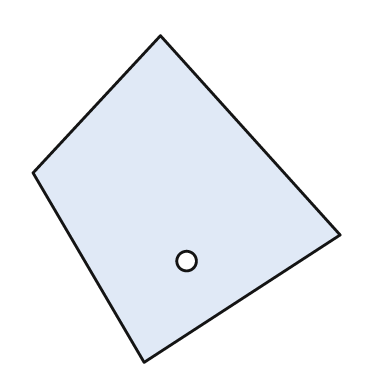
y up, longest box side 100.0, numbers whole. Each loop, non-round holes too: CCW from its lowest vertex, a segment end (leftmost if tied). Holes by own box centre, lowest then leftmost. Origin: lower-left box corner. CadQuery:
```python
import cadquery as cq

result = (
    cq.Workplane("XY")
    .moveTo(34.0, 0.0)
    .lineTo(94.0, 39.0)
    .lineTo(39.0, 100.0)
    .lineTo(0.0, 58.0)
    .close()
    .moveTo(47.0, 31.0)
    .circle(3.0)
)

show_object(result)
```